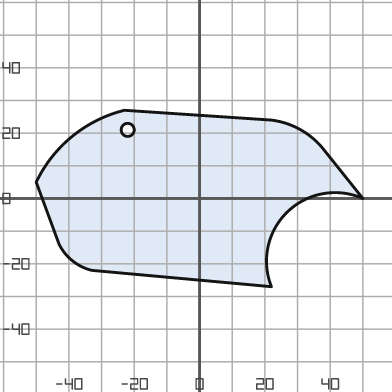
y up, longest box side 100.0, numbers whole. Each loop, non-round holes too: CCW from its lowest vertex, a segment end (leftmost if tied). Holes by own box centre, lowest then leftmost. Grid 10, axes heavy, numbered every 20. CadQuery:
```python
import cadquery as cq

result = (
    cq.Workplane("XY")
    .moveTo(22.0, -27.0)
    .threePointArc((27.0, -4.0), (50.0, 0.0))
    .lineTo(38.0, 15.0)
    .threePointArc((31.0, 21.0), (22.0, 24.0))
    .lineTo(-23.0, 27.0)
    .threePointArc((-39.0, 19.0), (-50.0, 5.0))
    .lineTo(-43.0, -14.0)
    .threePointArc((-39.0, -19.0), (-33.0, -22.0))
    .close()
    .moveTo(-22.0, 21.0)
    .circle(2.0)
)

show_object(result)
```